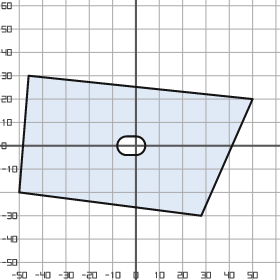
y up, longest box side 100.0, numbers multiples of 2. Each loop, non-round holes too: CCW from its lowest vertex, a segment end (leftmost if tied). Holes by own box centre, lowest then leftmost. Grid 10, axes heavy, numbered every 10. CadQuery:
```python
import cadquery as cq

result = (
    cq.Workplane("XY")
    .moveTo(28.0, -30.0)
    .lineTo(50.0, 20.0)
    .lineTo(-46.0, 30.0)
    .lineTo(-50.0, -20.0)
    .close()
    .moveTo(-4.0, -4.0)
    .lineTo(0.0, -4.0)
    .threePointArc((4.0, 0.0), (0.0, 4.0))
    .lineTo(-4.0, 4.0)
    .threePointArc((-8.0, 0.0), (-4.0, -4.0))
    .close()
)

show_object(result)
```